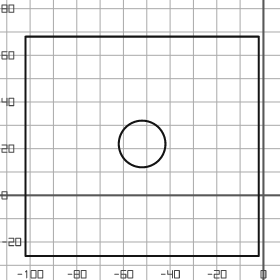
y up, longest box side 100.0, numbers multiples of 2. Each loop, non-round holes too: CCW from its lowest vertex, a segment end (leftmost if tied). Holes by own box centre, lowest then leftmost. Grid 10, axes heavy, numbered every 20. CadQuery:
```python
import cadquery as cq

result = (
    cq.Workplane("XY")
    .moveTo(-102.0, -26.0)
    .lineTo(-2.0, -26.0)
    .lineTo(-2.0, 68.0)
    .lineTo(-102.0, 68.0)
    .close()
    .moveTo(-52.0, 22.0)
    .circle(10.0)
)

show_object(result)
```